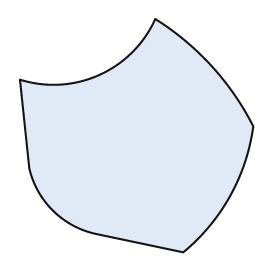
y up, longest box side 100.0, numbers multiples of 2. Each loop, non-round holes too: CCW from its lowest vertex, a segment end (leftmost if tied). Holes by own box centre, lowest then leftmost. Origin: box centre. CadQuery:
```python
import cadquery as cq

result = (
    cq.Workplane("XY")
    .moveTo(20.0, -50.0)
    .threePointArc((40.0, -26.0), (50.0, 4.0))
    .threePointArc((32.0, 30.0), (8.0, 50.0))
    .threePointArc((-16.0, 26.0), (-50.0, 24.0))
    .lineTo(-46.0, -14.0)
    .threePointArc((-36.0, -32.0), (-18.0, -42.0))
    .close()
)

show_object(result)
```